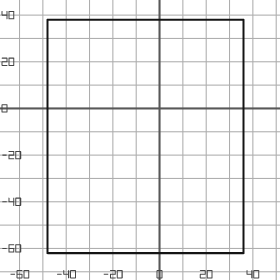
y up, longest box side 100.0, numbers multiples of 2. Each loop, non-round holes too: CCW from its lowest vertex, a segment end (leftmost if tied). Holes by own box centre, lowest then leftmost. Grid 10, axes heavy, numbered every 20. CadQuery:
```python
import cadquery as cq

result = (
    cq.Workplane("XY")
    .moveTo(-48.0, -62.0)
    .lineTo(36.0, -62.0)
    .lineTo(36.0, 38.0)
    .lineTo(-48.0, 38.0)
    .close()
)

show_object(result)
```